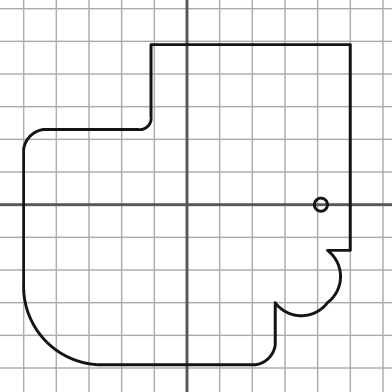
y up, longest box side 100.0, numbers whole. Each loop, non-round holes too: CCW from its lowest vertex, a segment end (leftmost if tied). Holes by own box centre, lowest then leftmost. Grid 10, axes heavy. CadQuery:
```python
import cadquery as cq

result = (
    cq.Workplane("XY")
    .moveTo(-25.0, -49.0)
    .lineTo(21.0, -49.0)
    .threePointArc((25.0, -47.0), (27.0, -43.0))
    .lineTo(27.0, -30.0)
    .threePointArc((35.0, -34.0), (43.0, -30.0))
    .threePointArc((47.0, -22.0), (43.0, -14.0))
    .lineTo(50.0, -14.0)
    .lineTo(50.0, 49.0)
    .lineTo(-11.0, 49.0)
    .lineTo(-11.0, 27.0)
    .threePointArc((-12.0, 24.0), (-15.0, 23.0))
    .lineTo(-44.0, 23.0)
    .threePointArc((-48.0, 21.0), (-50.0, 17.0))
    .lineTo(-50.0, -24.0)
    .threePointArc((-43.0, -42.0), (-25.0, -49.0))
    .close()
    .moveTo(41.0, 0.0)
    .circle(2.0)
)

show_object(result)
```